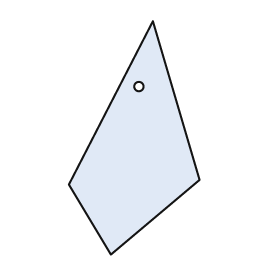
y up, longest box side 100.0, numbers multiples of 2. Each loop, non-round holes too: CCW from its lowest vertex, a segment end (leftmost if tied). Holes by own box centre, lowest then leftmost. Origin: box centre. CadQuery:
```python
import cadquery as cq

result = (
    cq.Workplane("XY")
    .moveTo(-10.0, -50.0)
    .lineTo(28.0, -18.0)
    .lineTo(8.0, 50.0)
    .lineTo(-28.0, -20.0)
    .close()
    .moveTo(2.0, 22.0)
    .circle(2.0)
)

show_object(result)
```